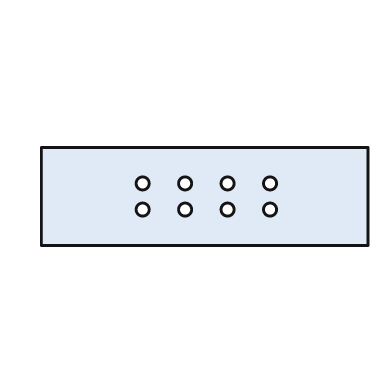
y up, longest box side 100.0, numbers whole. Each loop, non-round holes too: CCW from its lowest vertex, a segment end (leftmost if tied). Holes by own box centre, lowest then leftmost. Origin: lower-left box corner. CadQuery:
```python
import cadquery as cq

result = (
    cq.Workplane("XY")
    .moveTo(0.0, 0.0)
    .lineTo(100.0, 0.0)
    .lineTo(100.0, 30.0)
    .lineTo(0.0, 30.0)
    .close()
    .moveTo(31.0, 11.0)
    .circle(2.0)
    .moveTo(44.0, 11.0)
    .circle(2.0)
    .moveTo(57.0, 11.0)
    .circle(2.0)
    .moveTo(70.0, 11.0)
    .circle(2.0)
    .moveTo(31.0, 19.0)
    .circle(2.0)
    .moveTo(44.0, 19.0)
    .circle(2.0)
    .moveTo(57.0, 19.0)
    .circle(2.0)
    .moveTo(70.0, 19.0)
    .circle(2.0)
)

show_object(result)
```